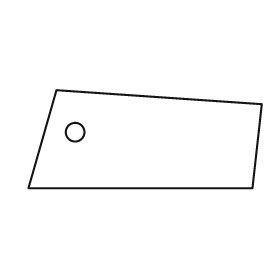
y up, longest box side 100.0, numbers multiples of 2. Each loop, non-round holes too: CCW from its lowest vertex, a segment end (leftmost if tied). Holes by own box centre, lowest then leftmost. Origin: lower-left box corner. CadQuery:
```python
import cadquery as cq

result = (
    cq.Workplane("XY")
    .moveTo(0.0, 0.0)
    .lineTo(96.0, 0.0)
    .lineTo(100.0, 36.0)
    .lineTo(12.0, 42.0)
    .close()
    .moveTo(20.0, 24.0)
    .circle(4.0)
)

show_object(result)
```